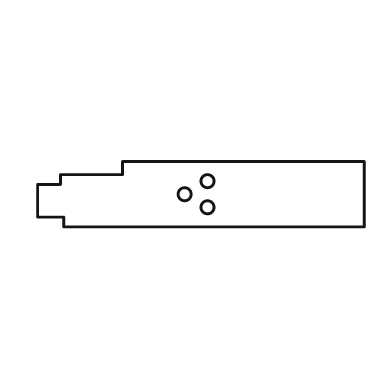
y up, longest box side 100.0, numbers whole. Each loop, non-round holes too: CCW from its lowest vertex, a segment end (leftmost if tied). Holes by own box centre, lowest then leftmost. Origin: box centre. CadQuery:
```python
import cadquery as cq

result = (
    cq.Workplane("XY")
    .moveTo(-42.0, -10.0)
    .lineTo(50.0, -10.0)
    .lineTo(50.0, 10.0)
    .lineTo(-24.0, 10.0)
    .lineTo(-24.0, 6.0)
    .lineTo(-43.0, 6.0)
    .lineTo(-43.0, 3.0)
    .lineTo(-50.0, 3.0)
    .lineTo(-50.0, -7.0)
    .lineTo(-42.0, -7.0)
    .close()
    .moveTo(2.0, -4.0)
    .circle(2.0)
    .moveTo(-5.0, 0.0)
    .circle(2.0)
    .moveTo(2.0, 4.0)
    .circle(2.0)
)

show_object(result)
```